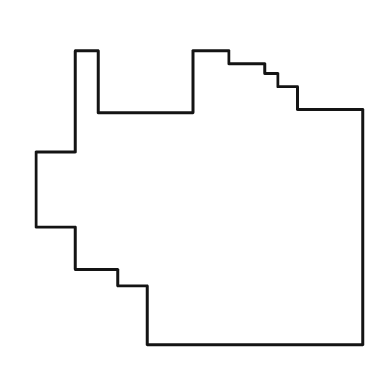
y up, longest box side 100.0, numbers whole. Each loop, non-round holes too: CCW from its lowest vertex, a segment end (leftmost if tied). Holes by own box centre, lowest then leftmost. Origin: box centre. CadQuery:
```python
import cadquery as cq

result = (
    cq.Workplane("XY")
    .moveTo(-16.0, -45.0)
    .lineTo(50.0, -45.0)
    .lineTo(50.0, 27.0)
    .lineTo(30.0, 27.0)
    .lineTo(30.0, 34.0)
    .lineTo(24.0, 34.0)
    .lineTo(24.0, 38.0)
    .lineTo(20.0, 38.0)
    .lineTo(20.0, 41.0)
    .lineTo(9.0, 41.0)
    .lineTo(9.0, 45.0)
    .lineTo(-2.0, 45.0)
    .lineTo(-2.0, 26.0)
    .lineTo(-31.0, 26.0)
    .lineTo(-31.0, 45.0)
    .lineTo(-38.0, 45.0)
    .lineTo(-38.0, 14.0)
    .lineTo(-50.0, 14.0)
    .lineTo(-50.0, -9.0)
    .lineTo(-38.0, -9.0)
    .lineTo(-38.0, -22.0)
    .lineTo(-25.0, -22.0)
    .lineTo(-25.0, -27.0)
    .lineTo(-16.0, -27.0)
    .close()
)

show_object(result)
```